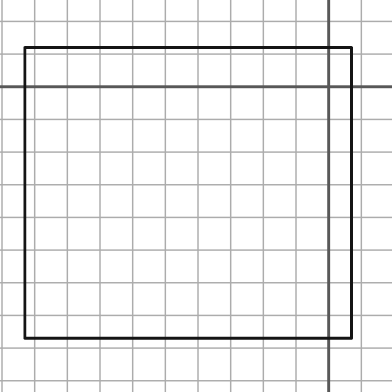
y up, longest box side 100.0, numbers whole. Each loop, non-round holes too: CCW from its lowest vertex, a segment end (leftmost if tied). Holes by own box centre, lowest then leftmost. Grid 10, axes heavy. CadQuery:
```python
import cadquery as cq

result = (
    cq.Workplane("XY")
    .moveTo(-93.0, -77.0)
    .lineTo(7.0, -77.0)
    .lineTo(7.0, 12.0)
    .lineTo(-93.0, 12.0)
    .close()
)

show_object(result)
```